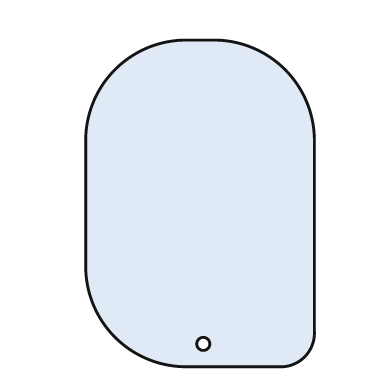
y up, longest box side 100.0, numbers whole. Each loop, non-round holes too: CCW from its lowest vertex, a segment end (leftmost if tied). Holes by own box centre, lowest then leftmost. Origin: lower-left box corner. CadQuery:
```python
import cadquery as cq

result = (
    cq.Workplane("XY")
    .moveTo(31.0, 0.0)
    .lineTo(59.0, 0.0)
    .threePointArc((67.0, 3.0), (70.0, 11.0))
    .lineTo(70.0, 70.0)
    .threePointArc((61.0, 91.0), (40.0, 100.0))
    .lineTo(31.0, 100.0)
    .threePointArc((9.0, 91.0), (0.0, 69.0))
    .lineTo(0.0, 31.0)
    .threePointArc((9.0, 9.0), (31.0, 0.0))
    .close()
    .moveTo(36.0, 7.0)
    .circle(2.0)
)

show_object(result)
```